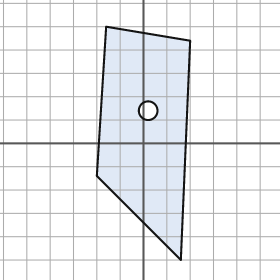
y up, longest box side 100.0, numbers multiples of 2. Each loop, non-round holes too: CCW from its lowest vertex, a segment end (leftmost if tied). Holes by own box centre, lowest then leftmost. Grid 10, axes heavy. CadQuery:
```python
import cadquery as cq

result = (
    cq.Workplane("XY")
    .moveTo(16.0, -50.0)
    .lineTo(20.0, 44.0)
    .lineTo(-16.0, 50.0)
    .lineTo(-20.0, -14.0)
    .close()
    .moveTo(2.0, 14.0)
    .circle(4.0)
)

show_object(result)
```